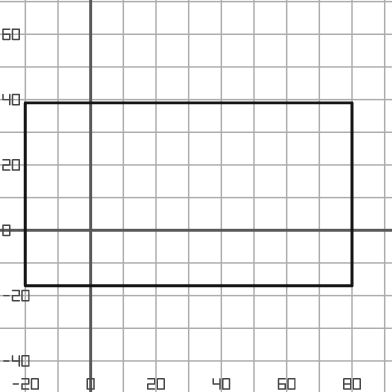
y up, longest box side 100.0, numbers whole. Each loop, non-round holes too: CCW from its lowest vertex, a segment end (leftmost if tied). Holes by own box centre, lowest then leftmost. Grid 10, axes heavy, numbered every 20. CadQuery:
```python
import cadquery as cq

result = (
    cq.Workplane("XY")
    .moveTo(-20.0, -17.0)
    .lineTo(80.0, -17.0)
    .lineTo(80.0, 39.0)
    .lineTo(-20.0, 39.0)
    .close()
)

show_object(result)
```